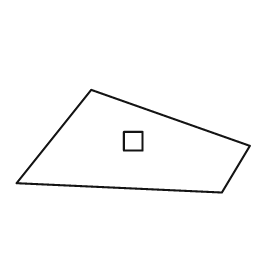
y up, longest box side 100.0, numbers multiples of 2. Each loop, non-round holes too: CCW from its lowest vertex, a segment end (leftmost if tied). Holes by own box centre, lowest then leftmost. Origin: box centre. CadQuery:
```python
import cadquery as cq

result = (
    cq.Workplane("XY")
    .moveTo(38.0, -22.0)
    .lineTo(50.0, -2.0)
    .lineTo(-18.0, 22.0)
    .lineTo(-50.0, -18.0)
    .close()
    .moveTo(-4.0, -4.0)
    .lineTo(4.0, -4.0)
    .lineTo(4.0, 4.0)
    .lineTo(-4.0, 4.0)
    .close()
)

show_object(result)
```